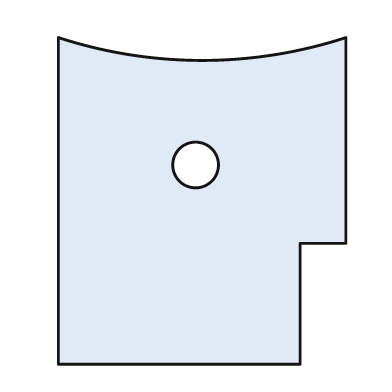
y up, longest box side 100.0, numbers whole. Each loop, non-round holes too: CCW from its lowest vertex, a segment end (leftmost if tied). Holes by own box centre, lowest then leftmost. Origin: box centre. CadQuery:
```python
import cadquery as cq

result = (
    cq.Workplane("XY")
    .moveTo(-44.0, -50.0)
    .lineTo(30.0, -50.0)
    .lineTo(30.0, -13.0)
    .lineTo(44.0, -13.0)
    .lineTo(44.0, 50.0)
    .threePointArc((0.0, 43.0), (-44.0, 50.0))
    .close()
    .moveTo(-2.0, 11.0)
    .circle(7.0)
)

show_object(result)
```